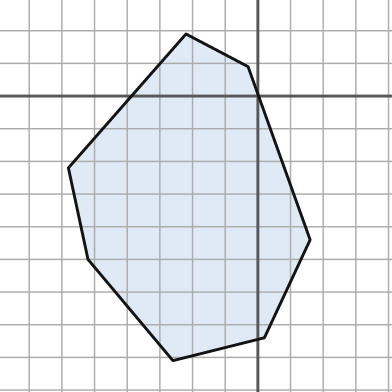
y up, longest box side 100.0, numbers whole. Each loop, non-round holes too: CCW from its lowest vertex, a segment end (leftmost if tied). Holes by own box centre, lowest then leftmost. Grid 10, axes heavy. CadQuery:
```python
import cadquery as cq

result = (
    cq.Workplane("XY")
    .moveTo(-26.0, -81.0)
    .lineTo(2.0, -74.0)
    .lineTo(16.0, -44.0)
    .lineTo(-3.0, 9.0)
    .lineTo(-22.0, 19.0)
    .lineTo(-58.0, -22.0)
    .lineTo(-52.0, -50.0)
    .close()
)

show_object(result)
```